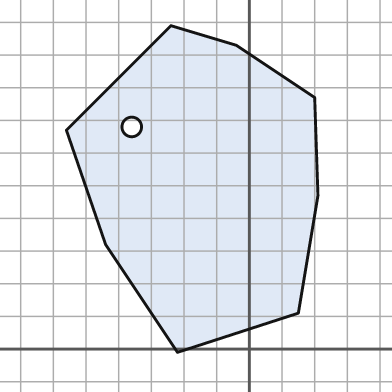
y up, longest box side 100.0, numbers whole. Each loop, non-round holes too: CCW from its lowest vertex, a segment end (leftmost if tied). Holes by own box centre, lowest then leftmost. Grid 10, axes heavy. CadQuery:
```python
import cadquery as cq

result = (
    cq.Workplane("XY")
    .moveTo(-22.0, -1.0)
    .lineTo(15.0, 11.0)
    .lineTo(21.0, 47.0)
    .lineTo(20.0, 77.0)
    .lineTo(-4.0, 93.0)
    .lineTo(-24.0, 99.0)
    .lineTo(-56.0, 67.0)
    .lineTo(-44.0, 32.0)
    .close()
    .moveTo(-36.0, 68.0)
    .circle(3.0)
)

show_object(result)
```